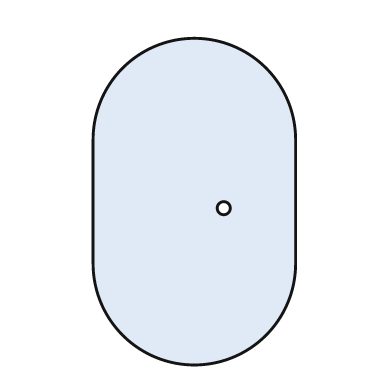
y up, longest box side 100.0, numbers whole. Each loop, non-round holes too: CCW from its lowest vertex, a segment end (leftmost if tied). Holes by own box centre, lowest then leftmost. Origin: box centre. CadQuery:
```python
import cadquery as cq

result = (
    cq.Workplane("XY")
    .moveTo(-31.0, -19.0)
    .threePointArc((0.0, -50.0), (31.0, -19.0))
    .lineTo(31.0, 19.0)
    .threePointArc((0.0, 50.0), (-31.0, 19.0))
    .close()
    .moveTo(9.0, -2.0)
    .circle(2.0)
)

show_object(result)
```